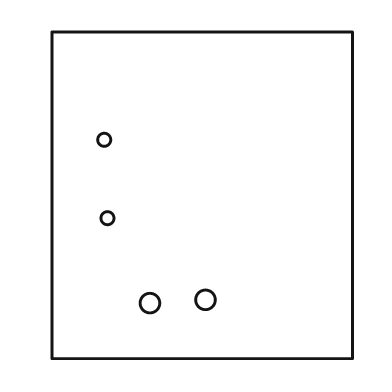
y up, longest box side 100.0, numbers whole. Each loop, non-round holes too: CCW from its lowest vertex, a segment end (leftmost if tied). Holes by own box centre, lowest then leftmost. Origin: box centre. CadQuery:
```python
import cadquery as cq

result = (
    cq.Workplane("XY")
    .moveTo(-46.0, -50.0)
    .lineTo(46.0, -50.0)
    .lineTo(46.0, 50.0)
    .lineTo(-46.0, 50.0)
    .close()
    .moveTo(-16.0, -33.0)
    .circle(3.0)
    .moveTo(1.0, -32.0)
    .circle(3.0)
    .moveTo(-29.0, -7.0)
    .circle(2.0)
    .moveTo(-30.0, 17.0)
    .circle(2.0)
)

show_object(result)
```